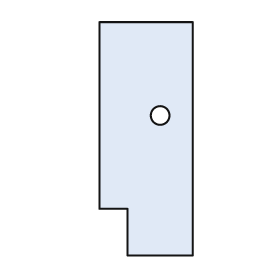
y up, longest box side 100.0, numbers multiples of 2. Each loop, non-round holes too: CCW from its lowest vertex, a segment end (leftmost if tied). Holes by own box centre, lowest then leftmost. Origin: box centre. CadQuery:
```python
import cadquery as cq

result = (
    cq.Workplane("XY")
    .moveTo(-8.0, -50.0)
    .lineTo(20.0, -50.0)
    .lineTo(20.0, 50.0)
    .lineTo(-20.0, 50.0)
    .lineTo(-20.0, -30.0)
    .lineTo(-8.0, -30.0)
    .close()
    .moveTo(6.0, 10.0)
    .circle(4.0)
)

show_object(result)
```